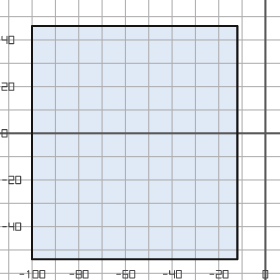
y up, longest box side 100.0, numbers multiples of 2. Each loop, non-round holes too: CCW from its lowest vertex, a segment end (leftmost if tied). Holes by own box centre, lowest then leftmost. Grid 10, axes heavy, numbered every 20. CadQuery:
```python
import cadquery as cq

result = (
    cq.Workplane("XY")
    .moveTo(-100.0, -54.0)
    .lineTo(-12.0, -54.0)
    .lineTo(-12.0, 46.0)
    .lineTo(-100.0, 46.0)
    .close()
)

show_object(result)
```